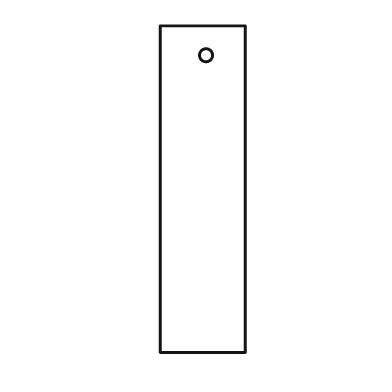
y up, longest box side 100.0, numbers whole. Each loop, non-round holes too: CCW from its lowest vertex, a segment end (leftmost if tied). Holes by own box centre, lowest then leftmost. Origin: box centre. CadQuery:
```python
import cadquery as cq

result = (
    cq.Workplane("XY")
    .moveTo(-13.0, -50.0)
    .lineTo(13.0, -50.0)
    .lineTo(13.0, 50.0)
    .lineTo(-13.0, 50.0)
    .close()
    .moveTo(1.0, 41.0)
    .circle(2.0)
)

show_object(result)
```